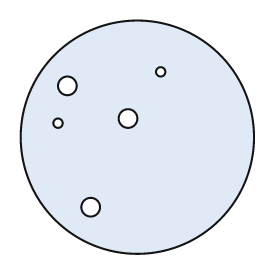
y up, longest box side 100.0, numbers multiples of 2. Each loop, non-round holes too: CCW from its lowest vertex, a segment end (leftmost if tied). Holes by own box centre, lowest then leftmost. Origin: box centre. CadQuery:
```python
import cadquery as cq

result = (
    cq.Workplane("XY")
    .moveTo(0.0, 0.0)
    .circle(50.0)
    .moveTo(-20.0, -30.0)
    .circle(4.0)
    .moveTo(-34.0, 6.0)
    .circle(2.0)
    .moveTo(-4.0, 8.0)
    .circle(4.0)
    .moveTo(-30.0, 22.0)
    .circle(4.0)
    .moveTo(10.0, 28.0)
    .circle(2.0)
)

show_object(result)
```